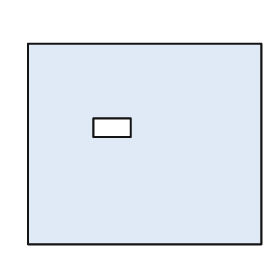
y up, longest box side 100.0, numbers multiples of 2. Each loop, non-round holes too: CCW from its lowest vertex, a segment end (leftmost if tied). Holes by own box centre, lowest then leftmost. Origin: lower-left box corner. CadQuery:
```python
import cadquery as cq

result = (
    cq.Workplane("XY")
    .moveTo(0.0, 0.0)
    .lineTo(100.0, 0.0)
    .lineTo(100.0, 86.0)
    .lineTo(0.0, 86.0)
    .close()
    .moveTo(28.0, 46.0)
    .lineTo(44.0, 46.0)
    .lineTo(44.0, 54.0)
    .lineTo(28.0, 54.0)
    .close()
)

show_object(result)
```